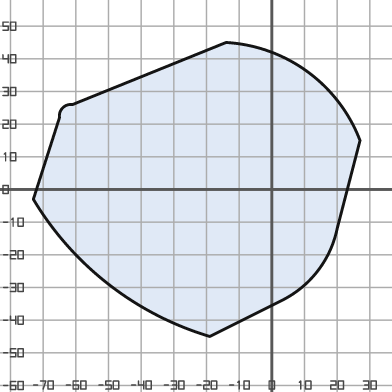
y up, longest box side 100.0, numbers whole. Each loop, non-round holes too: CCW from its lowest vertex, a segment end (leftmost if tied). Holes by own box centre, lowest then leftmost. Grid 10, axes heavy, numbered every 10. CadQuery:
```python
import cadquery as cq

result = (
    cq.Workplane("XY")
    .moveTo(-19.0, -45.0)
    .lineTo(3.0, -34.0)
    .threePointArc((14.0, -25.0), (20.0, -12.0))
    .lineTo(27.0, 15.0)
    .threePointArc((11.0, 36.0), (-14.0, 45.0))
    .lineTo(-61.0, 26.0)
    .threePointArc((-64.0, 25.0), (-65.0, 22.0))
    .lineTo(-73.0, -3.0)
    .threePointArc((-50.0, -29.0), (-19.0, -45.0))
    .close()
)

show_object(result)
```